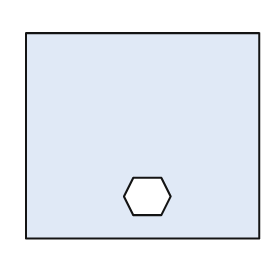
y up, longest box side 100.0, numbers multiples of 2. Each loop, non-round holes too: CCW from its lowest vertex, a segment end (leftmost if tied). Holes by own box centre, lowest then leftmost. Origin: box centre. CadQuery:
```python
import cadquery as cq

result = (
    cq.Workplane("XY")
    .moveTo(-50.0, -44.0)
    .lineTo(50.0, -44.0)
    .lineTo(50.0, 44.0)
    .lineTo(-50.0, 44.0)
    .close()
    .moveTo(-4.0, -34.0)
    .lineTo(8.0, -34.0)
    .lineTo(12.0, -26.0)
    .lineTo(8.0, -18.0)
    .lineTo(-4.0, -18.0)
    .lineTo(-8.0, -26.0)
    .close()
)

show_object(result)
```